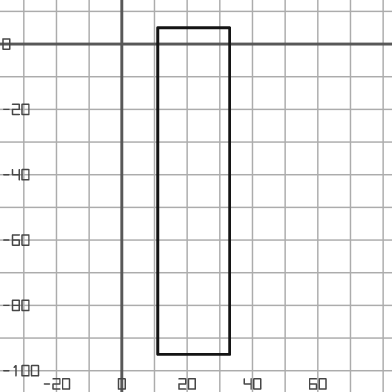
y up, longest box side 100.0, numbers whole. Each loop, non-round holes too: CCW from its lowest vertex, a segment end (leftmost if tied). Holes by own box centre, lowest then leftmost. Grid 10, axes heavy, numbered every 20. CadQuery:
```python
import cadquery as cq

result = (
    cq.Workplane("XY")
    .moveTo(11.0, -95.0)
    .lineTo(33.0, -95.0)
    .lineTo(33.0, 5.0)
    .lineTo(11.0, 5.0)
    .close()
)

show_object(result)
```